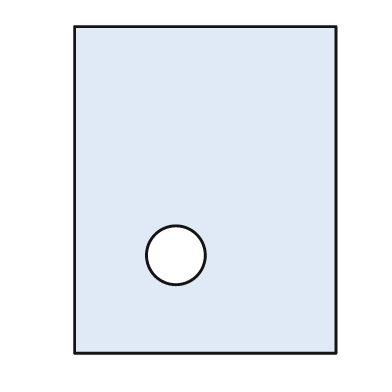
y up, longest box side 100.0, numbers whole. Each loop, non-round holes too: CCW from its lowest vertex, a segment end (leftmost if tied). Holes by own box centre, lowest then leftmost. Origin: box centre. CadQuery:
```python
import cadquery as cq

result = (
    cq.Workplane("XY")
    .moveTo(-40.0, -50.0)
    .lineTo(40.0, -50.0)
    .lineTo(40.0, 50.0)
    .lineTo(-40.0, 50.0)
    .close()
    .moveTo(-9.0, -20.0)
    .circle(9.0)
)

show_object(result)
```